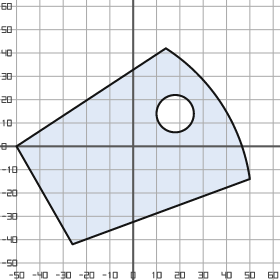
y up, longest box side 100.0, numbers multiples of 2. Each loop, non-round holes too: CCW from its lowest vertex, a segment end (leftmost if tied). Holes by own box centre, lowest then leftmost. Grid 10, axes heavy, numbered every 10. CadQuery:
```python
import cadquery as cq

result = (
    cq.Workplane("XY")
    .moveTo(-26.0, -42.0)
    .lineTo(50.0, -14.0)
    .threePointArc((38.0, 18.0), (14.0, 42.0))
    .lineTo(-50.0, 0.0)
    .close()
    .moveTo(18.0, 14.0)
    .circle(8.0)
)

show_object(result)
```